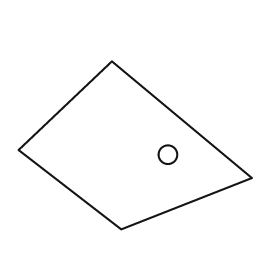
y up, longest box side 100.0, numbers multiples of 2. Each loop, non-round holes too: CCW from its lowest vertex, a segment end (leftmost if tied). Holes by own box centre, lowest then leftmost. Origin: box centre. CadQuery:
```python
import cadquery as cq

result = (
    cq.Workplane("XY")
    .moveTo(-6.0, -36.0)
    .lineTo(50.0, -14.0)
    .lineTo(-10.0, 36.0)
    .lineTo(-50.0, -2.0)
    .close()
    .moveTo(14.0, -4.0)
    .circle(4.0)
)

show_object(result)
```